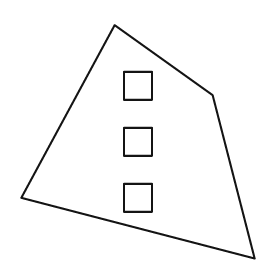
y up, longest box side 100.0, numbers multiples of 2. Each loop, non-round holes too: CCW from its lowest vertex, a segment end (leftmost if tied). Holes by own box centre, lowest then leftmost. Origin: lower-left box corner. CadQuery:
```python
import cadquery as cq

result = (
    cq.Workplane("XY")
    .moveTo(100.0, 0.0)
    .lineTo(82.0, 70.0)
    .lineTo(40.0, 100.0)
    .lineTo(0.0, 26.0)
    .close()
    .moveTo(44.0, 20.0)
    .lineTo(56.0, 20.0)
    .lineTo(56.0, 32.0)
    .lineTo(44.0, 32.0)
    .close()
    .moveTo(44.0, 44.0)
    .lineTo(56.0, 44.0)
    .lineTo(56.0, 56.0)
    .lineTo(44.0, 56.0)
    .close()
    .moveTo(44.0, 68.0)
    .lineTo(56.0, 68.0)
    .lineTo(56.0, 80.0)
    .lineTo(44.0, 80.0)
    .close()
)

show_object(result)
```